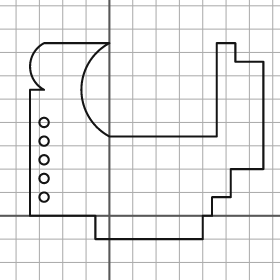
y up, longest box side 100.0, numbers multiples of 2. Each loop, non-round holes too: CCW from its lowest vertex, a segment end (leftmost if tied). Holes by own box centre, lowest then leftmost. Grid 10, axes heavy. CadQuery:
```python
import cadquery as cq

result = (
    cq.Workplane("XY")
    .moveTo(-6.0, -10.0)
    .lineTo(40.0, -10.0)
    .lineTo(40.0, 0.0)
    .lineTo(44.0, 0.0)
    .lineTo(44.0, 8.0)
    .lineTo(52.0, 8.0)
    .lineTo(52.0, 20.0)
    .lineTo(66.0, 20.0)
    .lineTo(66.0, 66.0)
    .lineTo(54.0, 66.0)
    .lineTo(54.0, 74.0)
    .lineTo(46.0, 74.0)
    .lineTo(46.0, 34.0)
    .lineTo(0.0, 34.0)
    .threePointArc((-12.0, 54.0), (0.0, 74.0))
    .lineTo(-28.0, 74.0)
    .threePointArc((-34.0, 64.0), (-28.0, 54.0))
    .lineTo(-34.0, 54.0)
    .lineTo(-34.0, 0.0)
    .lineTo(-6.0, 0.0)
    .close()
    .moveTo(-28.0, 8.0)
    .circle(2.0)
    .moveTo(-28.0, 16.0)
    .circle(2.0)
    .moveTo(-28.0, 24.0)
    .circle(2.0)
    .moveTo(-28.0, 32.0)
    .circle(2.0)
    .moveTo(-28.0, 40.0)
    .circle(2.0)
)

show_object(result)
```